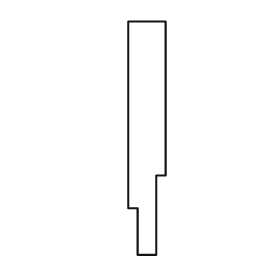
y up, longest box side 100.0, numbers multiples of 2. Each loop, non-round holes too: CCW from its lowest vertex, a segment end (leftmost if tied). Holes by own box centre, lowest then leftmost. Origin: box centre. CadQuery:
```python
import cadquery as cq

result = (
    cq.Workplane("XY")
    .moveTo(-4.0, -50.0)
    .lineTo(4.0, -50.0)
    .lineTo(4.0, -16.0)
    .lineTo(8.0, -16.0)
    .lineTo(8.0, 50.0)
    .lineTo(-8.0, 50.0)
    .lineTo(-8.0, -30.0)
    .lineTo(-4.0, -30.0)
    .close()
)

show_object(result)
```